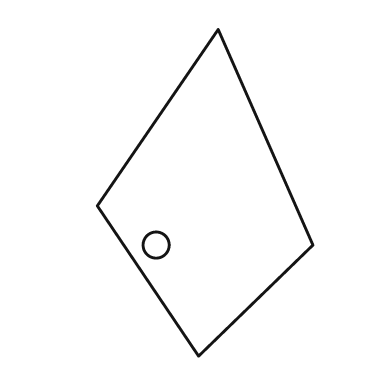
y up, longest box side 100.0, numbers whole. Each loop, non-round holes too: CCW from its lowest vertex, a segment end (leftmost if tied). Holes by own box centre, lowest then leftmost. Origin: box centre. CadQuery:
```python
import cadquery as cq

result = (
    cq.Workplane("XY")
    .moveTo(-2.0, -50.0)
    .lineTo(33.0, -16.0)
    .lineTo(4.0, 50.0)
    .lineTo(-33.0, -4.0)
    .close()
    .moveTo(-15.0, -16.0)
    .circle(4.0)
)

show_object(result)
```